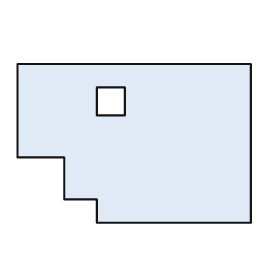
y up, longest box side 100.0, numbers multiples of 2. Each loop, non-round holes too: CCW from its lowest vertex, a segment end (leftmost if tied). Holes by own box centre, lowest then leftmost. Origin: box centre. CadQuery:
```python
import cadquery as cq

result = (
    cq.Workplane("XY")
    .moveTo(-16.0, -34.0)
    .lineTo(50.0, -34.0)
    .lineTo(50.0, 34.0)
    .lineTo(-50.0, 34.0)
    .lineTo(-50.0, -6.0)
    .lineTo(-30.0, -6.0)
    .lineTo(-30.0, -24.0)
    .lineTo(-16.0, -24.0)
    .close()
    .moveTo(-16.0, 12.0)
    .lineTo(-4.0, 12.0)
    .lineTo(-4.0, 24.0)
    .lineTo(-16.0, 24.0)
    .close()
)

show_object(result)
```